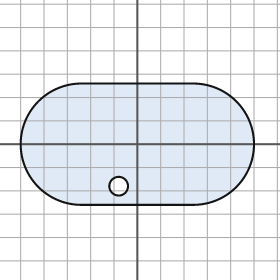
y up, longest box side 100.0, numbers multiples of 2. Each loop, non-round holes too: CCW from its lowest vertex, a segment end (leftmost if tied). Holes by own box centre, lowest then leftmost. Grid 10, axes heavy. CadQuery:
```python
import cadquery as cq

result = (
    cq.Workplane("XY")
    .moveTo(-24.0, -26.0)
    .lineTo(24.0, -26.0)
    .threePointArc((50.0, 0.0), (24.0, 26.0))
    .lineTo(-24.0, 26.0)
    .threePointArc((-50.0, 0.0), (-24.0, -26.0))
    .close()
    .moveTo(-8.0, -18.0)
    .circle(4.0)
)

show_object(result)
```